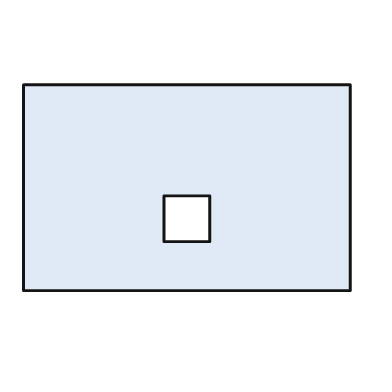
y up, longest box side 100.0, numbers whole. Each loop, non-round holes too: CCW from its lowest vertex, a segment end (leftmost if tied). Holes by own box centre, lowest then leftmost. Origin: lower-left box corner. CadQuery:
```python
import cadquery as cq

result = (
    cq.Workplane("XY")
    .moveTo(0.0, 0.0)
    .lineTo(100.0, 0.0)
    .lineTo(100.0, 63.0)
    .lineTo(0.0, 63.0)
    .close()
    .moveTo(43.0, 15.0)
    .lineTo(57.0, 15.0)
    .lineTo(57.0, 29.0)
    .lineTo(43.0, 29.0)
    .close()
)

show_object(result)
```